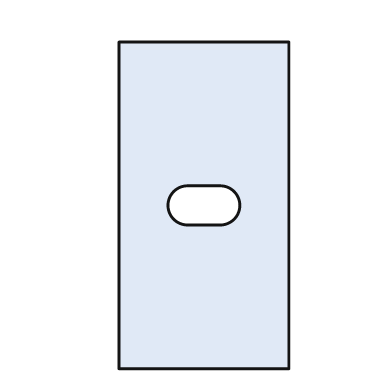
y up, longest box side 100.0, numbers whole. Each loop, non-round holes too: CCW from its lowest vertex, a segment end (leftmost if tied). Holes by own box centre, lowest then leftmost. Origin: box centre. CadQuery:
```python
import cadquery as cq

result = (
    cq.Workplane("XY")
    .moveTo(-26.0, -50.0)
    .lineTo(26.0, -50.0)
    .lineTo(26.0, 50.0)
    .lineTo(-26.0, 50.0)
    .close()
    .moveTo(-5.0, -6.0)
    .lineTo(5.0, -6.0)
    .threePointArc((11.0, 0.0), (5.0, 6.0))
    .lineTo(-5.0, 6.0)
    .threePointArc((-11.0, 0.0), (-5.0, -6.0))
    .close()
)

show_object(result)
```